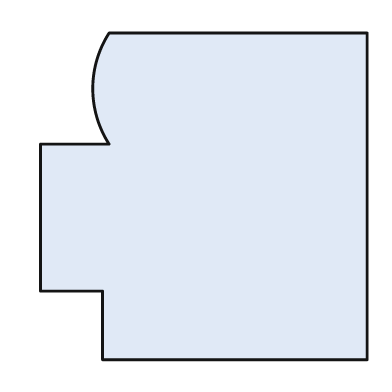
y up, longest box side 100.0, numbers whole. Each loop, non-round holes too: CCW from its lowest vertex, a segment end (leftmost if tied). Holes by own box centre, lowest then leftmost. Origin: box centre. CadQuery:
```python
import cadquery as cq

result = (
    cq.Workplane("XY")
    .moveTo(-31.0, -50.0)
    .lineTo(50.0, -50.0)
    .lineTo(50.0, 50.0)
    .lineTo(-29.0, 50.0)
    .threePointArc((-34.0, 33.0), (-29.0, 16.0))
    .lineTo(-50.0, 16.0)
    .lineTo(-50.0, -29.0)
    .lineTo(-31.0, -29.0)
    .close()
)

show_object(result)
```